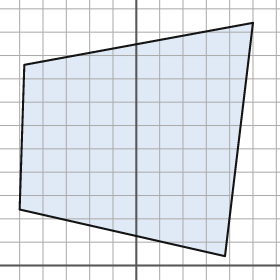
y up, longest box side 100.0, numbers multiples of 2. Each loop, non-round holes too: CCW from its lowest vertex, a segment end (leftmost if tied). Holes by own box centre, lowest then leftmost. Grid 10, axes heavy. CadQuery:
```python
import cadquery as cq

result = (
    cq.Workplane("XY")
    .moveTo(38.0, 4.0)
    .lineTo(50.0, 104.0)
    .lineTo(-48.0, 86.0)
    .lineTo(-50.0, 24.0)
    .close()
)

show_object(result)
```